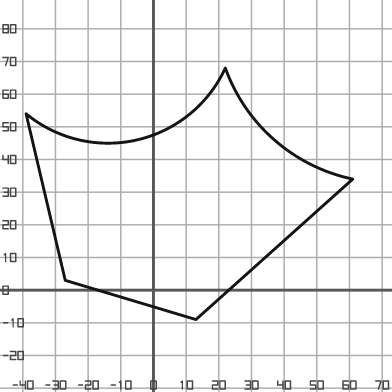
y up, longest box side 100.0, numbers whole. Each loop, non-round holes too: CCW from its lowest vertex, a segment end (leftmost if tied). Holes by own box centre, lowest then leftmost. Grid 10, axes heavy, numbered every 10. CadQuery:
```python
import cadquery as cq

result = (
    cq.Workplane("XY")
    .moveTo(13.0, -9.0)
    .lineTo(61.0, 34.0)
    .threePointArc((37.0, 46.0), (22.0, 68.0))
    .threePointArc((-5.0, 46.0), (-39.0, 54.0))
    .lineTo(-27.0, 3.0)
    .close()
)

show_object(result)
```